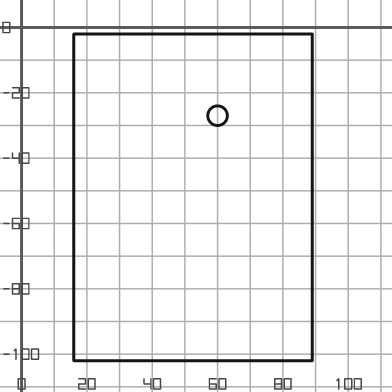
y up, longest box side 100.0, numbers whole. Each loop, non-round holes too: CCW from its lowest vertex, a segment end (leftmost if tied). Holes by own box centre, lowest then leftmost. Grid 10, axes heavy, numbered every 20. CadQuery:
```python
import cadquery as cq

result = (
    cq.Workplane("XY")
    .moveTo(16.0, -102.0)
    .lineTo(89.0, -102.0)
    .lineTo(89.0, -2.0)
    .lineTo(16.0, -2.0)
    .close()
    .moveTo(60.0, -27.0)
    .circle(3.0)
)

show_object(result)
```